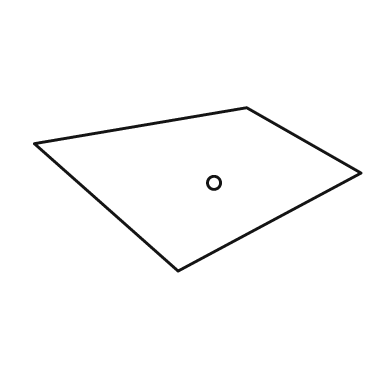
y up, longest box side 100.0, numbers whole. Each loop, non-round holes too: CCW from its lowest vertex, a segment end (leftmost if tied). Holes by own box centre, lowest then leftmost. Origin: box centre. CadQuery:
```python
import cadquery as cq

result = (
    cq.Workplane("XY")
    .moveTo(-6.0, -25.0)
    .lineTo(50.0, 5.0)
    .lineTo(15.0, 25.0)
    .lineTo(-50.0, 14.0)
    .close()
    .moveTo(5.0, 2.0)
    .circle(2.0)
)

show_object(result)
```